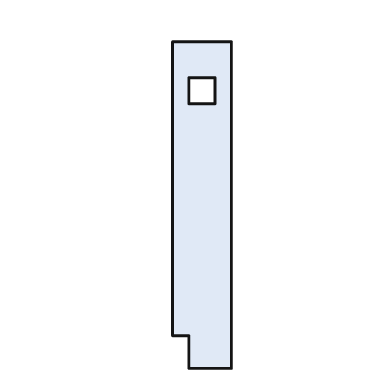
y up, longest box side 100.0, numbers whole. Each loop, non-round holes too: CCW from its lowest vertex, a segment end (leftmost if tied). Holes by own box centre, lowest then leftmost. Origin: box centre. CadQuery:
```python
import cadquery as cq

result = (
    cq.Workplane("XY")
    .moveTo(-4.0, -50.0)
    .lineTo(9.0, -50.0)
    .lineTo(9.0, 50.0)
    .lineTo(-9.0, 50.0)
    .lineTo(-9.0, -40.0)
    .lineTo(-4.0, -40.0)
    .close()
    .moveTo(-4.0, 31.0)
    .lineTo(4.0, 31.0)
    .lineTo(4.0, 39.0)
    .lineTo(-4.0, 39.0)
    .close()
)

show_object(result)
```